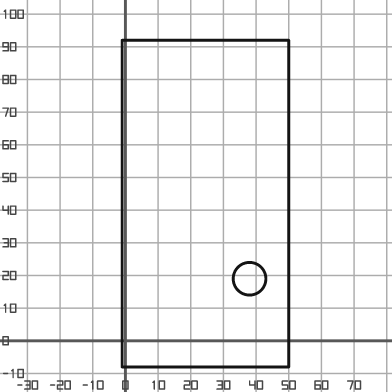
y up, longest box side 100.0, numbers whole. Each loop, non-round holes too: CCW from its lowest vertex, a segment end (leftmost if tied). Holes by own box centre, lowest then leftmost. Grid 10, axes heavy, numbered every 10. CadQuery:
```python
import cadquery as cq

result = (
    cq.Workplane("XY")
    .moveTo(-1.0, -8.0)
    .lineTo(50.0, -8.0)
    .lineTo(50.0, 92.0)
    .lineTo(-1.0, 92.0)
    .close()
    .moveTo(38.0, 19.0)
    .circle(5.0)
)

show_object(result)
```